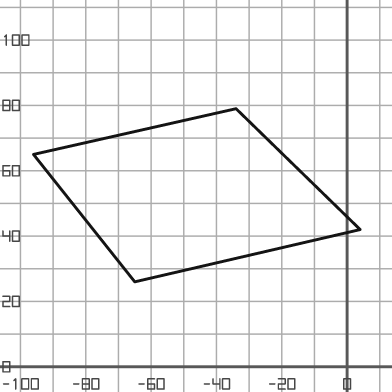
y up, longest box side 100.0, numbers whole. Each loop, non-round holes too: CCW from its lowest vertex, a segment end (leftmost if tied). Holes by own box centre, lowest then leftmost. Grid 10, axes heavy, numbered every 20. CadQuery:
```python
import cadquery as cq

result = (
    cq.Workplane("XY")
    .moveTo(-65.0, 26.0)
    .lineTo(4.0, 42.0)
    .lineTo(-34.0, 79.0)
    .lineTo(-96.0, 65.0)
    .close()
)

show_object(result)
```